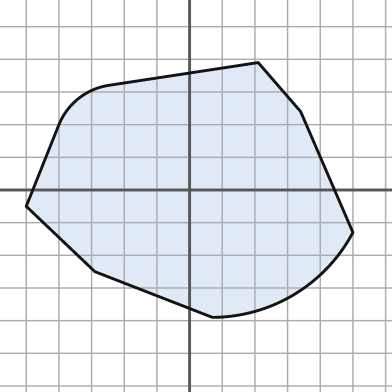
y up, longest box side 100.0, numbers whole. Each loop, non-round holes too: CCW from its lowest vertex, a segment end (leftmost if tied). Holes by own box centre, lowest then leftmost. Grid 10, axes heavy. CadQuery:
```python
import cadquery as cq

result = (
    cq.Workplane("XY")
    .moveTo(7.0, -39.0)
    .threePointArc((32.0, -32.0), (50.0, -13.0))
    .lineTo(34.0, 24.0)
    .lineTo(21.0, 39.0)
    .lineTo(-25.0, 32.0)
    .threePointArc((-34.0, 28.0), (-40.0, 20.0))
    .lineTo(-50.0, -5.0)
    .lineTo(-29.0, -25.0)
    .close()
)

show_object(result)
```